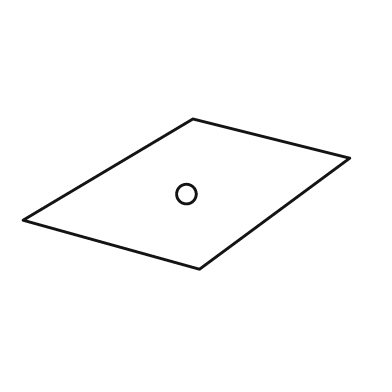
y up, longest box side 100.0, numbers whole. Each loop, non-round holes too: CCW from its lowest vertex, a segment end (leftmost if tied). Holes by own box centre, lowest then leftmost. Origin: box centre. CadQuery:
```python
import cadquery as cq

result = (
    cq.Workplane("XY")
    .moveTo(4.0, -23.0)
    .lineTo(50.0, 11.0)
    .lineTo(2.0, 23.0)
    .lineTo(-50.0, -8.0)
    .close()
    .moveTo(0.0, 0.0)
    .circle(3.0)
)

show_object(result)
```